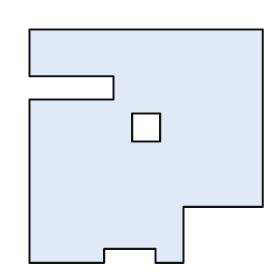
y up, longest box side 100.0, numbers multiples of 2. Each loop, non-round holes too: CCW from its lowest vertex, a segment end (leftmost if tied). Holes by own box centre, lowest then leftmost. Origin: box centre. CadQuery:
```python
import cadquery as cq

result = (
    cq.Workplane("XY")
    .moveTo(-50.0, -50.0)
    .lineTo(-18.0, -50.0)
    .lineTo(-18.0, -44.0)
    .lineTo(4.0, -44.0)
    .lineTo(4.0, -50.0)
    .lineTo(16.0, -50.0)
    .lineTo(16.0, -26.0)
    .lineTo(50.0, -26.0)
    .lineTo(50.0, 50.0)
    .lineTo(-50.0, 50.0)
    .lineTo(-50.0, 30.0)
    .lineTo(-14.0, 30.0)
    .lineTo(-14.0, 20.0)
    .lineTo(-50.0, 20.0)
    .close()
    .moveTo(-6.0, 2.0)
    .lineTo(6.0, 2.0)
    .lineTo(6.0, 14.0)
    .lineTo(-6.0, 14.0)
    .close()
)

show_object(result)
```